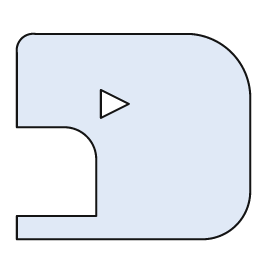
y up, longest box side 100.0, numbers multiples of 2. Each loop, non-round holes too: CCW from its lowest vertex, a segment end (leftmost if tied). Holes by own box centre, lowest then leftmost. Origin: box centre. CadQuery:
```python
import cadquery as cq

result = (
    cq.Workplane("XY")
    .moveTo(-50.0, -44.0)
    .lineTo(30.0, -44.0)
    .threePointArc((44.0, -38.0), (50.0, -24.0))
    .lineTo(50.0, 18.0)
    .threePointArc((42.0, 36.0), (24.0, 44.0))
    .lineTo(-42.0, 44.0)
    .threePointArc((-48.0, 42.0), (-50.0, 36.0))
    .lineTo(-50.0, 4.0)
    .lineTo(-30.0, 4.0)
    .threePointArc((-20.0, 0.0), (-16.0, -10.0))
    .lineTo(-16.0, -34.0)
    .lineTo(-50.0, -34.0)
    .close()
    .moveTo(-14.0, 8.0)
    .lineTo(-2.0, 14.0)
    .lineTo(-14.0, 20.0)
    .close()
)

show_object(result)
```